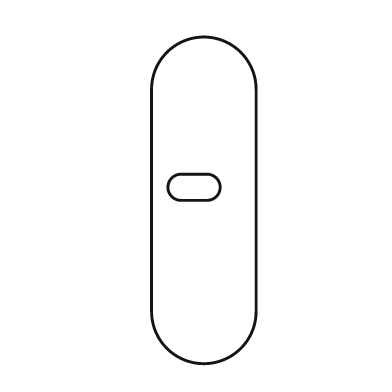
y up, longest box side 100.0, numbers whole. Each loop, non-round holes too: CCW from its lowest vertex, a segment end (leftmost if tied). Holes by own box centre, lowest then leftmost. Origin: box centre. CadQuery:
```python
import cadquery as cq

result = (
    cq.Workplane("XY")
    .moveTo(-16.0, -34.0)
    .threePointArc((0.0, -50.0), (16.0, -34.0))
    .lineTo(16.0, 34.0)
    .threePointArc((0.0, 50.0), (-16.0, 34.0))
    .close()
    .moveTo(-7.0, 0.0)
    .lineTo(1.0, 0.0)
    .threePointArc((5.0, 4.0), (1.0, 8.0))
    .lineTo(-7.0, 8.0)
    .threePointArc((-11.0, 4.0), (-7.0, 0.0))
    .close()
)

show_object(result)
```